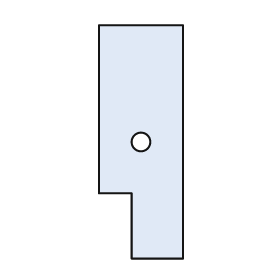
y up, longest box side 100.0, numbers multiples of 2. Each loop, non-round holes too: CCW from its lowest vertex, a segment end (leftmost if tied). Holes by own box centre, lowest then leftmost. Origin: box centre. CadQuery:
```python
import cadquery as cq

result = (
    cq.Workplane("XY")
    .moveTo(-4.0, -50.0)
    .lineTo(18.0, -50.0)
    .lineTo(18.0, 50.0)
    .lineTo(-18.0, 50.0)
    .lineTo(-18.0, -22.0)
    .lineTo(-4.0, -22.0)
    .close()
    .moveTo(0.0, 0.0)
    .circle(4.0)
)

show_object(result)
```